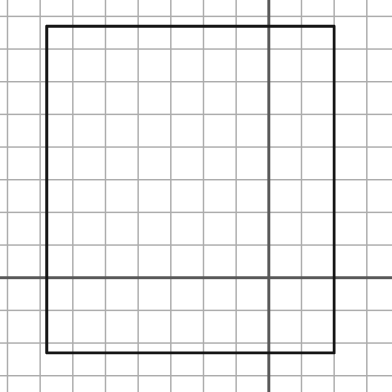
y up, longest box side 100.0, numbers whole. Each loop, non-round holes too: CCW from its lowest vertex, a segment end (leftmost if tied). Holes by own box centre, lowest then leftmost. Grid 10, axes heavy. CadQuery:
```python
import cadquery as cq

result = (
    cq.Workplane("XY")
    .moveTo(-68.0, -23.0)
    .lineTo(20.0, -23.0)
    .lineTo(20.0, 77.0)
    .lineTo(-68.0, 77.0)
    .close()
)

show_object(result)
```